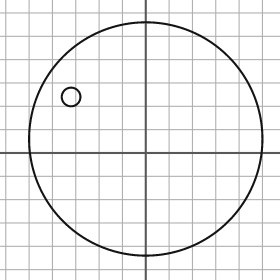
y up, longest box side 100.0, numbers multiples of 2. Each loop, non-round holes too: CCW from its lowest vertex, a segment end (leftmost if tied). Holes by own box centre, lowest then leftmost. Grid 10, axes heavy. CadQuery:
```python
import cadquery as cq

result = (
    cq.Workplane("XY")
    .moveTo(0.0, 6.0)
    .circle(50.0)
    .moveTo(-32.0, 24.0)
    .circle(4.0)
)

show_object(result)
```